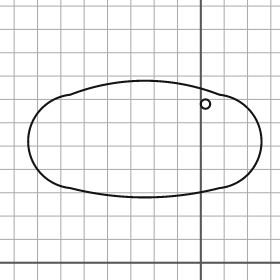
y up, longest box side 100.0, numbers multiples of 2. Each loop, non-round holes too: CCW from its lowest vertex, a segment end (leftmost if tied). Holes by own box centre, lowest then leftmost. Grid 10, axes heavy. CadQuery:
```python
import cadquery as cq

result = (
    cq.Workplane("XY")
    .moveTo(-56.0, 32.0)
    .threePointArc((-24.0, 28.0), (8.0, 32.0))
    .threePointArc((26.0, 52.0), (8.0, 72.0))
    .threePointArc((-24.0, 78.0), (-56.0, 72.0))
    .threePointArc((-74.0, 52.0), (-56.0, 32.0))
    .close()
    .moveTo(2.0, 68.0)
    .circle(2.0)
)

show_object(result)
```